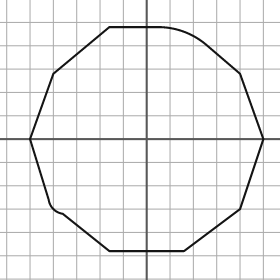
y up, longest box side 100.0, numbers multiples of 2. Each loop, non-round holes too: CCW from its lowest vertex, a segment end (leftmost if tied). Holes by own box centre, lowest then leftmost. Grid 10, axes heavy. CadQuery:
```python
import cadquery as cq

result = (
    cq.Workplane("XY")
    .moveTo(-16.0, -48.0)
    .lineTo(16.0, -48.0)
    .lineTo(40.0, -30.0)
    .lineTo(50.0, 0.0)
    .lineTo(40.0, 28.0)
    .lineTo(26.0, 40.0)
    .threePointArc((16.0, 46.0), (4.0, 48.0))
    .lineTo(-16.0, 48.0)
    .lineTo(-40.0, 28.0)
    .lineTo(-50.0, 0.0)
    .lineTo(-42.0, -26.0)
    .threePointArc((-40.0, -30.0), (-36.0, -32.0))
    .close()
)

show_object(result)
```